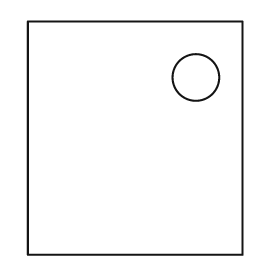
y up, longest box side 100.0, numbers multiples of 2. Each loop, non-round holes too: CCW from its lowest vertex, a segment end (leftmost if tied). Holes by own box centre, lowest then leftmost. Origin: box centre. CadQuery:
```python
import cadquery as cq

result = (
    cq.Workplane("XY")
    .moveTo(-46.0, -50.0)
    .lineTo(46.0, -50.0)
    .lineTo(46.0, 50.0)
    .lineTo(-46.0, 50.0)
    .close()
    .moveTo(26.0, 26.0)
    .circle(10.0)
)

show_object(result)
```